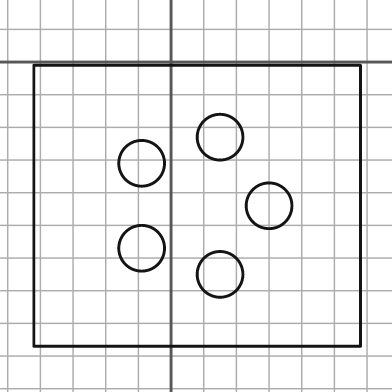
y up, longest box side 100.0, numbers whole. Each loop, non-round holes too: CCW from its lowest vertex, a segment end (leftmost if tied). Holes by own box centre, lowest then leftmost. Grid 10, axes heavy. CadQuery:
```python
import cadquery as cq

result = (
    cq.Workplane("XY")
    .moveTo(-42.0, -87.0)
    .lineTo(58.0, -87.0)
    .lineTo(58.0, -1.0)
    .lineTo(-42.0, -1.0)
    .close()
    .moveTo(15.0, -65.0)
    .circle(7.0)
    .moveTo(-9.0, -57.0)
    .circle(7.0)
    .moveTo(30.0, -44.0)
    .circle(7.0)
    .moveTo(-9.0, -31.0)
    .circle(7.0)
    .moveTo(15.0, -23.0)
    .circle(7.0)
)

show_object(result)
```